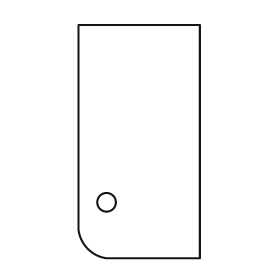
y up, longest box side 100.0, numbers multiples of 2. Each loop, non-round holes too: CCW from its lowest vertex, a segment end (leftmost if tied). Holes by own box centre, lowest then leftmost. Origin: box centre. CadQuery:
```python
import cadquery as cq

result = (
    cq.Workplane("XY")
    .moveTo(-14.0, -50.0)
    .lineTo(26.0, -50.0)
    .lineTo(26.0, 50.0)
    .lineTo(-26.0, 50.0)
    .lineTo(-26.0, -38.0)
    .threePointArc((-22.0, -46.0), (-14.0, -50.0))
    .close()
    .moveTo(-14.0, -26.0)
    .circle(4.0)
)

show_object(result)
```